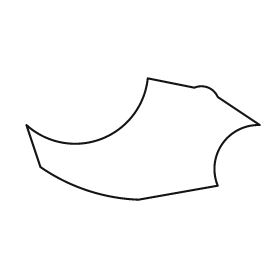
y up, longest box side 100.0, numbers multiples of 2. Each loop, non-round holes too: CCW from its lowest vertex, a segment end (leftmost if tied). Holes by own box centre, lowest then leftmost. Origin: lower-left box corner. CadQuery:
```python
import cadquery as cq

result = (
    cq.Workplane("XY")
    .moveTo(48.0, 0.0)
    .lineTo(82.0, 6.0)
    .threePointArc((84.0, 24.0), (100.0, 32.0))
    .lineTo(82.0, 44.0)
    .threePointArc((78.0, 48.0), (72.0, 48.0))
    .lineTo(52.0, 52.0)
    .threePointArc((32.0, 26.0), (0.0, 32.0))
    .lineTo(6.0, 14.0)
    .threePointArc((26.0, 4.0), (48.0, 0.0))
    .close()
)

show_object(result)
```